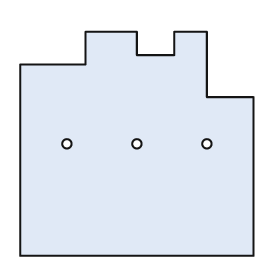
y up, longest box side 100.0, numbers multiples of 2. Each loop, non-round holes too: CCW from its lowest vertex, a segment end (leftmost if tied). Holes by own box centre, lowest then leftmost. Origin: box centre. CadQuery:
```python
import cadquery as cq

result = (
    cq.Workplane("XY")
    .moveTo(-50.0, -48.0)
    .lineTo(50.0, -48.0)
    .lineTo(50.0, 20.0)
    .lineTo(30.0, 20.0)
    .lineTo(30.0, 48.0)
    .lineTo(16.0, 48.0)
    .lineTo(16.0, 38.0)
    .lineTo(0.0, 38.0)
    .lineTo(0.0, 48.0)
    .lineTo(-22.0, 48.0)
    .lineTo(-22.0, 34.0)
    .lineTo(-50.0, 34.0)
    .close()
    .moveTo(-30.0, 0.0)
    .circle(2.0)
    .moveTo(0.0, 0.0)
    .circle(2.0)
    .moveTo(30.0, 0.0)
    .circle(2.0)
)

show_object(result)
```